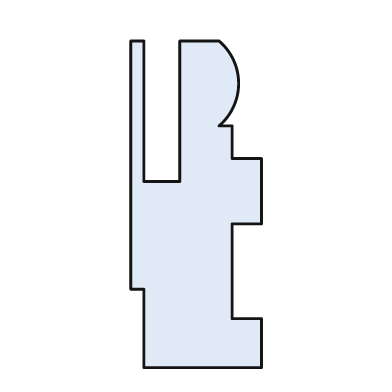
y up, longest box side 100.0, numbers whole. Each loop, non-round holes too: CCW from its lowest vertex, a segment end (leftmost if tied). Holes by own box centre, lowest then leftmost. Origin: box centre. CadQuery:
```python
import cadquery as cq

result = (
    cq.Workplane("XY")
    .moveTo(-16.0, -50.0)
    .lineTo(20.0, -50.0)
    .lineTo(20.0, -35.0)
    .lineTo(11.0, -35.0)
    .lineTo(11.0, -6.0)
    .lineTo(20.0, -6.0)
    .lineTo(20.0, 14.0)
    .lineTo(11.0, 14.0)
    .lineTo(11.0, 24.0)
    .lineTo(7.0, 24.0)
    .threePointArc((13.0, 37.0), (7.0, 50.0))
    .lineTo(-5.0, 50.0)
    .lineTo(-5.0, 7.0)
    .lineTo(-16.0, 7.0)
    .lineTo(-16.0, 50.0)
    .lineTo(-20.0, 50.0)
    .lineTo(-20.0, -26.0)
    .lineTo(-16.0, -26.0)
    .close()
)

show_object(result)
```